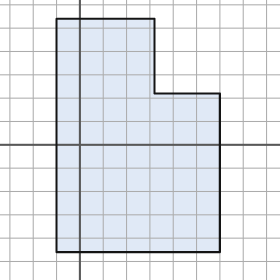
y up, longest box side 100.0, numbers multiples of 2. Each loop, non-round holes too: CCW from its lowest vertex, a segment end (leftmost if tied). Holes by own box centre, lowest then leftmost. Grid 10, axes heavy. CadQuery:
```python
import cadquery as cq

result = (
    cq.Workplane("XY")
    .moveTo(-10.0, -46.0)
    .lineTo(60.0, -46.0)
    .lineTo(60.0, 22.0)
    .lineTo(32.0, 22.0)
    .lineTo(32.0, 54.0)
    .lineTo(-10.0, 54.0)
    .close()
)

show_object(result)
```